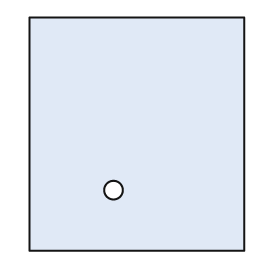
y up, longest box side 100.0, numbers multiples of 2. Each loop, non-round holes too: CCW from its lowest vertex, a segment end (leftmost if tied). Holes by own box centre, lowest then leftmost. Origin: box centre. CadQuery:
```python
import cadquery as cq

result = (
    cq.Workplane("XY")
    .moveTo(-46.0, -50.0)
    .lineTo(46.0, -50.0)
    .lineTo(46.0, 50.0)
    .lineTo(-46.0, 50.0)
    .close()
    .moveTo(-10.0, -24.0)
    .circle(4.0)
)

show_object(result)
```